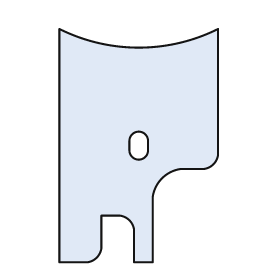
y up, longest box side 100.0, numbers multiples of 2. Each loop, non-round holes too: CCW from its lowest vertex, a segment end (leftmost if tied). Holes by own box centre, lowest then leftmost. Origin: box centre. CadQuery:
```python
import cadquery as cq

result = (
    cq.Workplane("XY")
    .moveTo(-34.0, -50.0)
    .lineTo(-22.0, -50.0)
    .threePointArc((-18.0, -48.0), (-16.0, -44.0))
    .lineTo(-16.0, -30.0)
    .lineTo(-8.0, -30.0)
    .threePointArc((-4.0, -32.0), (-2.0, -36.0))
    .lineTo(-2.0, -50.0)
    .lineTo(6.0, -50.0)
    .lineTo(6.0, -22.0)
    .threePointArc((10.0, -14.0), (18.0, -10.0))
    .lineTo(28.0, -10.0)
    .threePointArc((32.0, -8.0), (34.0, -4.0))
    .lineTo(34.0, 50.0)
    .threePointArc((0.0, 42.0), (-34.0, 50.0))
    .close()
    .moveTo(-4.0, -2.0)
    .threePointArc((0.0, -6.0), (4.0, -2.0))
    .lineTo(4.0, 2.0)
    .threePointArc((0.0, 6.0), (-4.0, 2.0))
    .close()
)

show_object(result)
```